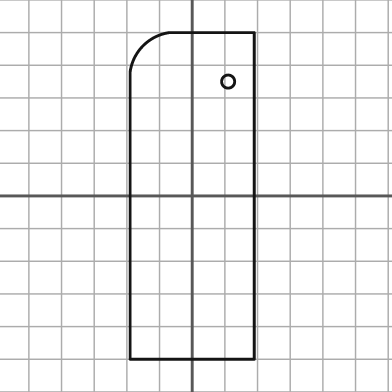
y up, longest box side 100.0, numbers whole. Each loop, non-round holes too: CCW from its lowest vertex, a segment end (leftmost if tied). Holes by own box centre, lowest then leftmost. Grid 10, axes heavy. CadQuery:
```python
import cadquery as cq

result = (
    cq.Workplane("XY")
    .moveTo(-19.0, -50.0)
    .lineTo(19.0, -50.0)
    .lineTo(19.0, 50.0)
    .lineTo(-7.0, 50.0)
    .threePointArc((-15.0, 46.0), (-19.0, 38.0))
    .close()
    .moveTo(11.0, 35.0)
    .circle(2.0)
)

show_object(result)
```